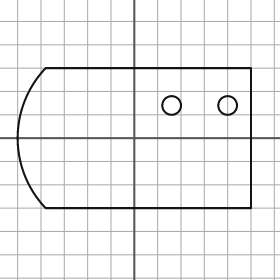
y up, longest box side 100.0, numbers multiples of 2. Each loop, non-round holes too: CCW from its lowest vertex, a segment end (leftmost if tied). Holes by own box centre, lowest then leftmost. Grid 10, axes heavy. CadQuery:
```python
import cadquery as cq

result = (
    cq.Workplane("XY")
    .moveTo(-38.0, -30.0)
    .lineTo(50.0, -30.0)
    .lineTo(50.0, 30.0)
    .lineTo(-38.0, 30.0)
    .threePointArc((-50.0, 0.0), (-38.0, -30.0))
    .close()
    .moveTo(16.0, 14.0)
    .circle(4.0)
    .moveTo(40.0, 14.0)
    .circle(4.0)
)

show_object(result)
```